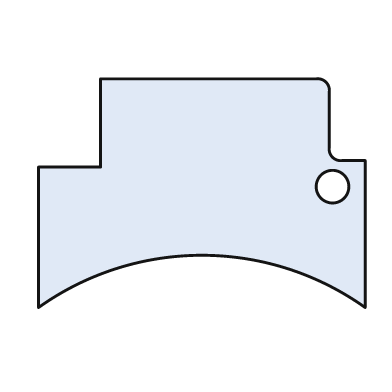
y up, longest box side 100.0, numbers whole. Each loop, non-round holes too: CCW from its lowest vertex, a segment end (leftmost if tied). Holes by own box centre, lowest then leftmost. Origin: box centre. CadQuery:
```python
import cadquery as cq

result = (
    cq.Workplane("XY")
    .moveTo(-50.0, -35.0)
    .threePointArc((0.0, -19.0), (50.0, -35.0))
    .lineTo(50.0, 10.0)
    .lineTo(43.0, 10.0)
    .threePointArc((40.0, 11.0), (39.0, 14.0))
    .lineTo(39.0, 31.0)
    .threePointArc((38.0, 34.0), (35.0, 35.0))
    .lineTo(-31.0, 35.0)
    .lineTo(-31.0, 8.0)
    .lineTo(-50.0, 8.0)
    .close()
    .moveTo(40.0, 2.0)
    .circle(5.0)
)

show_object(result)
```